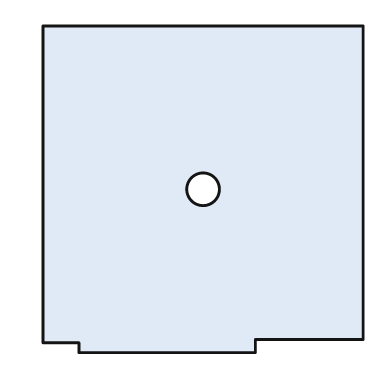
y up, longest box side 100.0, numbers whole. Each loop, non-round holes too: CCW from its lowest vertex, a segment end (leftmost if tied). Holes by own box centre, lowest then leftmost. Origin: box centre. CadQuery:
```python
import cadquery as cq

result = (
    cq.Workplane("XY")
    .moveTo(-38.0, -50.0)
    .lineTo(16.0, -50.0)
    .lineTo(16.0, -46.0)
    .lineTo(49.0, -46.0)
    .lineTo(49.0, 50.0)
    .lineTo(-49.0, 50.0)
    .lineTo(-49.0, -47.0)
    .lineTo(-38.0, -47.0)
    .close()
    .moveTo(0.0, 0.0)
    .circle(5.0)
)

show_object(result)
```